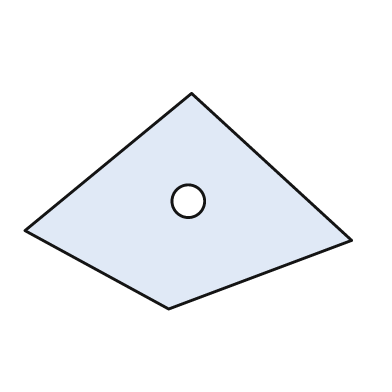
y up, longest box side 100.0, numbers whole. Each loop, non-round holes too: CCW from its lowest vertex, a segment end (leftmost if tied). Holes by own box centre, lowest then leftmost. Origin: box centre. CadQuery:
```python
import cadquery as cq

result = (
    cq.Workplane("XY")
    .moveTo(-6.0, -33.0)
    .lineTo(50.0, -12.0)
    .lineTo(1.0, 33.0)
    .lineTo(-50.0, -9.0)
    .close()
    .moveTo(0.0, 0.0)
    .circle(5.0)
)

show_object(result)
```